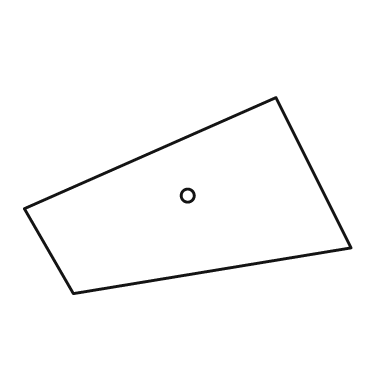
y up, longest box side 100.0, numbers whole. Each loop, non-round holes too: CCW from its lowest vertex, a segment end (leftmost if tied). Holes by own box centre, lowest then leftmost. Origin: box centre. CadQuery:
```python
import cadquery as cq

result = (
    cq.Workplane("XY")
    .moveTo(-35.0, -30.0)
    .lineTo(50.0, -16.0)
    .lineTo(27.0, 30.0)
    .lineTo(-50.0, -4.0)
    .close()
    .moveTo(0.0, 0.0)
    .circle(2.0)
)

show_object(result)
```